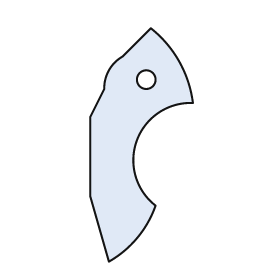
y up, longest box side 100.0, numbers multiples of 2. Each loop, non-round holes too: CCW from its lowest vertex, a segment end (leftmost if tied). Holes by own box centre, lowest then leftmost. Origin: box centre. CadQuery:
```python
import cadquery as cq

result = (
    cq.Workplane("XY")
    .moveTo(-14.0, -50.0)
    .threePointArc((-2.0, -40.0), (6.0, -26.0))
    .threePointArc((-2.0, 2.0), (22.0, 18.0))
    .threePointArc((16.0, 36.0), (4.0, 50.0))
    .lineTo(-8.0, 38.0)
    .threePointArc((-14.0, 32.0), (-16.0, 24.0))
    .lineTo(-22.0, 12.0)
    .lineTo(-22.0, -22.0)
    .close()
    .moveTo(2.0, 28.0)
    .circle(4.0)
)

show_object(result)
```